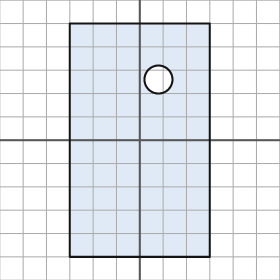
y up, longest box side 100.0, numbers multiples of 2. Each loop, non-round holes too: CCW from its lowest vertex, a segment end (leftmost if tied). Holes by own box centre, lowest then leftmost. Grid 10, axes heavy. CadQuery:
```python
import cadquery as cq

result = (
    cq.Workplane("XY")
    .moveTo(-30.0, -50.0)
    .lineTo(30.0, -50.0)
    .lineTo(30.0, 50.0)
    .lineTo(-30.0, 50.0)
    .close()
    .moveTo(8.0, 26.0)
    .circle(6.0)
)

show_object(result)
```